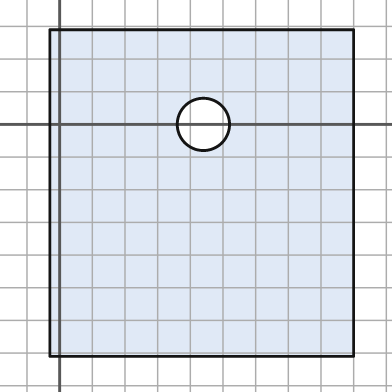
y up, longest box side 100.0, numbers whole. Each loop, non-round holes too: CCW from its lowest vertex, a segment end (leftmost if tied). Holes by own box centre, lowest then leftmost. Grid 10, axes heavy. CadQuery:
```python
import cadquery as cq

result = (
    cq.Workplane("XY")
    .moveTo(-3.0, -71.0)
    .lineTo(90.0, -71.0)
    .lineTo(90.0, 29.0)
    .lineTo(-3.0, 29.0)
    .close()
    .moveTo(44.0, 0.0)
    .circle(8.0)
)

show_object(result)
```